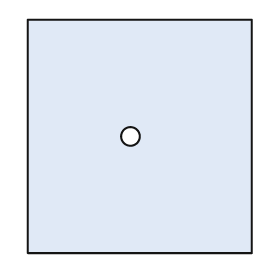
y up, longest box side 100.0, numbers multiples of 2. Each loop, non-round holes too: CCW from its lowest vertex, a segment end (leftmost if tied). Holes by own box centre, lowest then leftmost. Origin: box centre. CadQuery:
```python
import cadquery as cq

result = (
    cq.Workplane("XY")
    .moveTo(-48.0, -50.0)
    .lineTo(48.0, -50.0)
    .lineTo(48.0, 50.0)
    .lineTo(-48.0, 50.0)
    .close()
    .moveTo(-4.0, 0.0)
    .circle(4.0)
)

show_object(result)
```